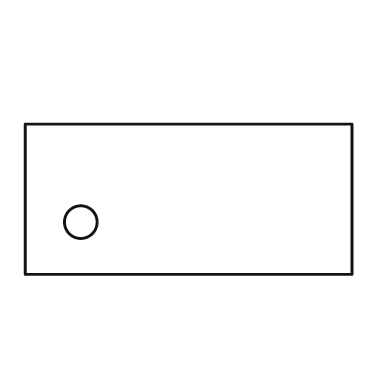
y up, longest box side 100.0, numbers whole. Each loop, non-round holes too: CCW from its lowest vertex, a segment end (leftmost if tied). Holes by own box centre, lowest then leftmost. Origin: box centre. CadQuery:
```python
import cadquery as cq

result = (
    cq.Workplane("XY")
    .moveTo(-50.0, -23.0)
    .lineTo(50.0, -23.0)
    .lineTo(50.0, 23.0)
    .lineTo(-50.0, 23.0)
    .close()
    .moveTo(-33.0, -7.0)
    .circle(5.0)
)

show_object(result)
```